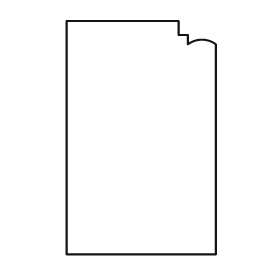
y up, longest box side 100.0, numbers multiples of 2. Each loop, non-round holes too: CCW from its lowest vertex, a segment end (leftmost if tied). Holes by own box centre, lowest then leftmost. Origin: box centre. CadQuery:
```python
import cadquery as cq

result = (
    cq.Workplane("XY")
    .moveTo(-32.0, -50.0)
    .lineTo(32.0, -50.0)
    .lineTo(32.0, 40.0)
    .threePointArc((26.0, 42.0), (20.0, 40.0))
    .lineTo(20.0, 44.0)
    .lineTo(16.0, 44.0)
    .lineTo(16.0, 50.0)
    .lineTo(-32.0, 50.0)
    .close()
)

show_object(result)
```